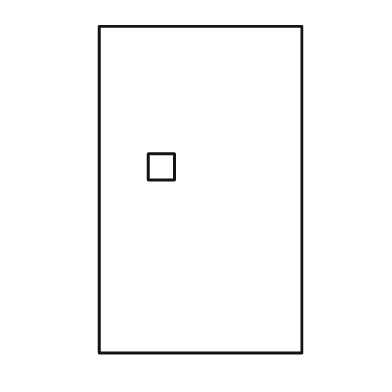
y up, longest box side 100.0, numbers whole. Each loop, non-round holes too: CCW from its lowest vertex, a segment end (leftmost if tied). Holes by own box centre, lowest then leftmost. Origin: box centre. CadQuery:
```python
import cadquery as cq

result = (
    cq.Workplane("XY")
    .moveTo(-31.0, -50.0)
    .lineTo(31.0, -50.0)
    .lineTo(31.0, 50.0)
    .lineTo(-31.0, 50.0)
    .close()
    .moveTo(-16.0, 3.0)
    .lineTo(-8.0, 3.0)
    .lineTo(-8.0, 11.0)
    .lineTo(-16.0, 11.0)
    .close()
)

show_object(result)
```